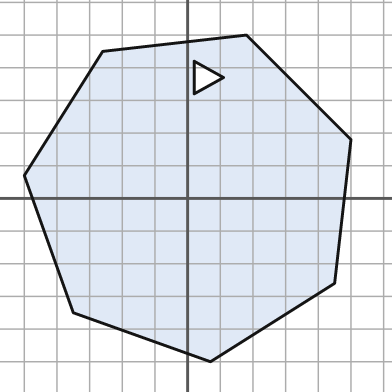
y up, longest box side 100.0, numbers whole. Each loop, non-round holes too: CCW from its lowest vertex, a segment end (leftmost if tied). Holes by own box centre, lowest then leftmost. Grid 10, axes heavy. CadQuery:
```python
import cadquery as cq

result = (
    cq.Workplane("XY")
    .moveTo(7.0, -50.0)
    .lineTo(45.0, -26.0)
    .lineTo(50.0, 18.0)
    .lineTo(18.0, 50.0)
    .lineTo(-26.0, 45.0)
    .lineTo(-50.0, 7.0)
    .lineTo(-35.0, -35.0)
    .close()
    .moveTo(2.0, 32.0)
    .lineTo(11.0, 37.0)
    .lineTo(2.0, 42.0)
    .close()
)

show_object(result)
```